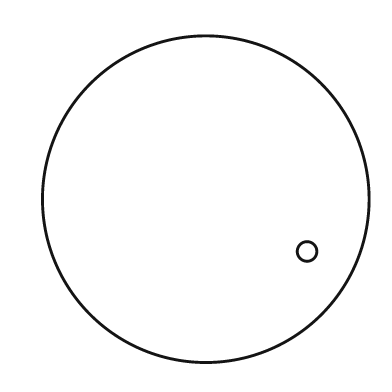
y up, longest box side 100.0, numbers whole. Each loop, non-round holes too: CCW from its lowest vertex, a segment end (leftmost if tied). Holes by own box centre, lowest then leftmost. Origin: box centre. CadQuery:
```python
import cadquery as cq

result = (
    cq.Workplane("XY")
    .moveTo(0.0, 0.0)
    .circle(50.0)
    .moveTo(31.0, -16.0)
    .circle(3.0)
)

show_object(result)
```